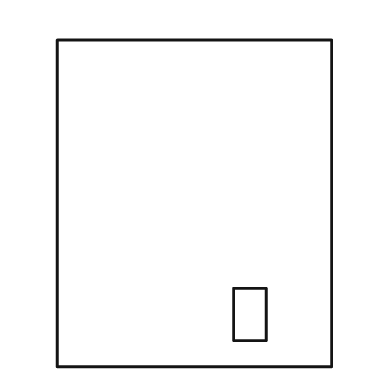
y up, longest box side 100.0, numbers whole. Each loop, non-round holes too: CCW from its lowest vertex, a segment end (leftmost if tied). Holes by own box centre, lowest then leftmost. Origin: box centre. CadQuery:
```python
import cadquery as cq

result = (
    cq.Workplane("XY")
    .moveTo(-42.0, -50.0)
    .lineTo(42.0, -50.0)
    .lineTo(42.0, 50.0)
    .lineTo(-42.0, 50.0)
    .close()
    .moveTo(12.0, -42.0)
    .lineTo(22.0, -42.0)
    .lineTo(22.0, -26.0)
    .lineTo(12.0, -26.0)
    .close()
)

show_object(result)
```